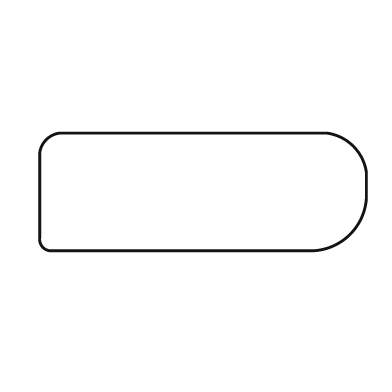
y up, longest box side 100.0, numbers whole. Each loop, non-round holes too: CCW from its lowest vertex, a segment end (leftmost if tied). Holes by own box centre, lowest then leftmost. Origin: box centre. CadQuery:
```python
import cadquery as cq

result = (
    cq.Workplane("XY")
    .moveTo(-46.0, -18.0)
    .lineTo(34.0, -18.0)
    .threePointArc((45.0, -13.0), (50.0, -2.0))
    .lineTo(50.0, 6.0)
    .threePointArc((46.0, 14.0), (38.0, 18.0))
    .lineTo(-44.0, 18.0)
    .threePointArc((-48.0, 16.0), (-50.0, 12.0))
    .lineTo(-50.0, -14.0)
    .threePointArc((-49.0, -17.0), (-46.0, -18.0))
    .close()
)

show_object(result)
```